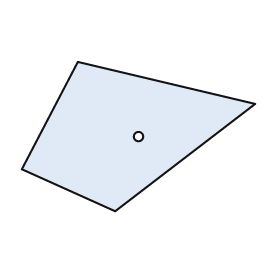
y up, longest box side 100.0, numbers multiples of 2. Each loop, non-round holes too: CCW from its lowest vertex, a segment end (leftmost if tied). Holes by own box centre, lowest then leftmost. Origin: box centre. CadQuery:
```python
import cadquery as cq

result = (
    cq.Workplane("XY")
    .moveTo(-10.0, -32.0)
    .lineTo(50.0, 14.0)
    .lineTo(-26.0, 32.0)
    .lineTo(-50.0, -14.0)
    .close()
    .moveTo(0.0, 0.0)
    .circle(2.0)
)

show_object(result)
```